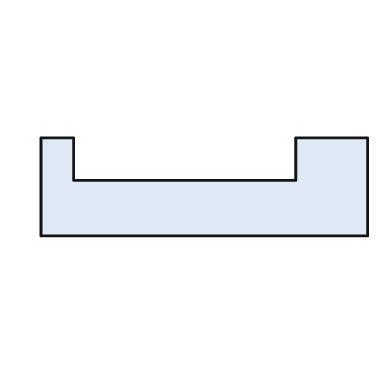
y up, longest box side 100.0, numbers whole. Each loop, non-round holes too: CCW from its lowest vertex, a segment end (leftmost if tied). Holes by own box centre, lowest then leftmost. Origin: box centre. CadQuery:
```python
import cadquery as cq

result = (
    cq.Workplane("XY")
    .moveTo(-50.0, -15.0)
    .lineTo(50.0, -15.0)
    .lineTo(50.0, 15.0)
    .lineTo(28.0, 15.0)
    .lineTo(28.0, 2.0)
    .lineTo(-40.0, 2.0)
    .lineTo(-40.0, 15.0)
    .lineTo(-50.0, 15.0)
    .close()
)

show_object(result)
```